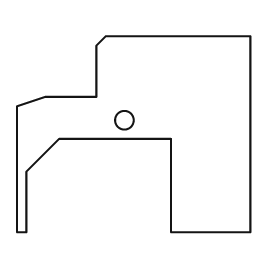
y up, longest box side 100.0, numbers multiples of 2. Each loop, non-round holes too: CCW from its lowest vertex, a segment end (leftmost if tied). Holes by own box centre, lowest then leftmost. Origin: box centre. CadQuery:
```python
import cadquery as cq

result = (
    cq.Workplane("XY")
    .moveTo(-50.0, -42.0)
    .lineTo(-46.0, -42.0)
    .lineTo(-46.0, -16.0)
    .lineTo(-32.0, -2.0)
    .lineTo(16.0, -2.0)
    .lineTo(16.0, -42.0)
    .lineTo(50.0, -42.0)
    .lineTo(50.0, 42.0)
    .lineTo(-12.0, 42.0)
    .lineTo(-16.0, 38.0)
    .lineTo(-16.0, 16.0)
    .lineTo(-38.0, 16.0)
    .lineTo(-50.0, 12.0)
    .close()
    .moveTo(-4.0, 6.0)
    .circle(4.0)
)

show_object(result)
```